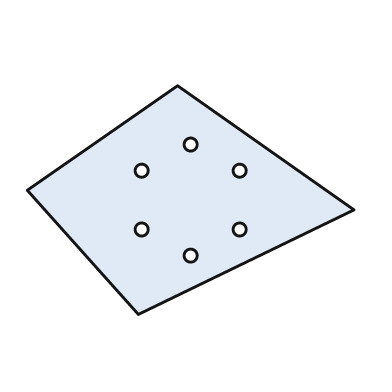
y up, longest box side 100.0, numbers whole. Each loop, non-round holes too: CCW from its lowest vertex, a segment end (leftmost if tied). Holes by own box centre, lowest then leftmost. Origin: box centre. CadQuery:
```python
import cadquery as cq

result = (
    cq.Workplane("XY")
    .moveTo(-16.0, -35.0)
    .lineTo(50.0, -3.0)
    .lineTo(-4.0, 35.0)
    .lineTo(-50.0, 3.0)
    .close()
    .moveTo(0.0, -17.0)
    .circle(2.0)
    .moveTo(-15.0, -9.0)
    .circle(2.0)
    .moveTo(15.0, -9.0)
    .circle(2.0)
    .moveTo(-15.0, 9.0)
    .circle(2.0)
    .moveTo(15.0, 9.0)
    .circle(2.0)
    .moveTo(0.0, 17.0)
    .circle(2.0)
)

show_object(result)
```